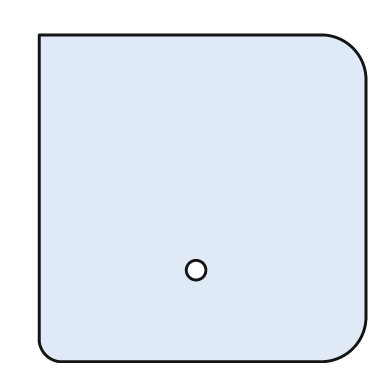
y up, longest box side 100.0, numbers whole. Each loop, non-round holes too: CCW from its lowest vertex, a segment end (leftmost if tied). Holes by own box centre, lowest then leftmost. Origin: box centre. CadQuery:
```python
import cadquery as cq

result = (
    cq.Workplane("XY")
    .moveTo(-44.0, -50.0)
    .lineTo(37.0, -50.0)
    .threePointArc((46.0, -46.0), (50.0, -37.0))
    .lineTo(50.0, 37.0)
    .threePointArc((46.0, 46.0), (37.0, 50.0))
    .lineTo(-50.0, 50.0)
    .lineTo(-50.0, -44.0)
    .threePointArc((-48.0, -48.0), (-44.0, -50.0))
    .close()
    .moveTo(-2.0, -22.0)
    .circle(3.0)
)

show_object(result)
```